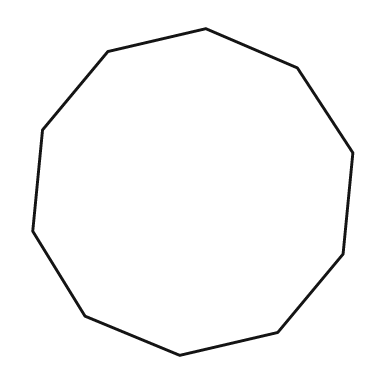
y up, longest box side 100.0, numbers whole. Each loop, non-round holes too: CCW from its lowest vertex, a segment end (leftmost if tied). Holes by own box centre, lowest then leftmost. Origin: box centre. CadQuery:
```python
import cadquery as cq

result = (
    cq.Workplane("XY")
    .moveTo(-4.0, -50.0)
    .lineTo(26.0, -43.0)
    .lineTo(46.0, -19.0)
    .lineTo(49.0, 12.0)
    .lineTo(32.0, 38.0)
    .lineTo(4.0, 50.0)
    .lineTo(-26.0, 43.0)
    .lineTo(-46.0, 19.0)
    .lineTo(-49.0, -12.0)
    .lineTo(-33.0, -38.0)
    .close()
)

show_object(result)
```